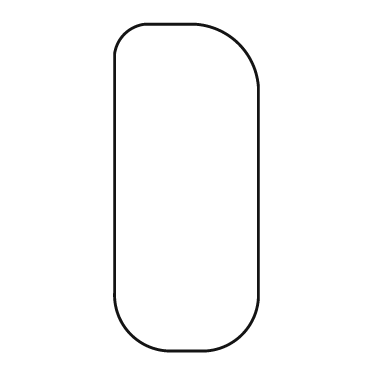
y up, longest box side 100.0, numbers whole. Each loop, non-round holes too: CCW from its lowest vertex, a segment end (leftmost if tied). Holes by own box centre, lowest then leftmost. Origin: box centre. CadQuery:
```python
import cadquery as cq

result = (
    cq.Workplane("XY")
    .moveTo(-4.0, -50.0)
    .lineTo(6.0, -50.0)
    .threePointArc((17.0, -45.0), (22.0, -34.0))
    .lineTo(22.0, 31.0)
    .threePointArc((16.0, 44.0), (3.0, 50.0))
    .lineTo(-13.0, 50.0)
    .threePointArc((-19.0, 47.0), (-22.0, 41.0))
    .lineTo(-22.0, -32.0)
    .threePointArc((-17.0, -45.0), (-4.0, -50.0))
    .close()
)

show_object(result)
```